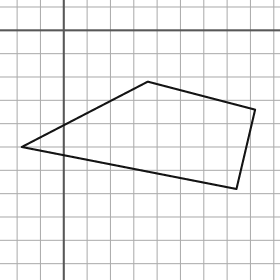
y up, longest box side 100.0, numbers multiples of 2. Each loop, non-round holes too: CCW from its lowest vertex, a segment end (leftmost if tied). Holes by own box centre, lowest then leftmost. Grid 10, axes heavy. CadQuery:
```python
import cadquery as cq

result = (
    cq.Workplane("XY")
    .moveTo(74.0, -68.0)
    .lineTo(82.0, -34.0)
    .lineTo(36.0, -22.0)
    .lineTo(-18.0, -50.0)
    .close()
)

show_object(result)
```